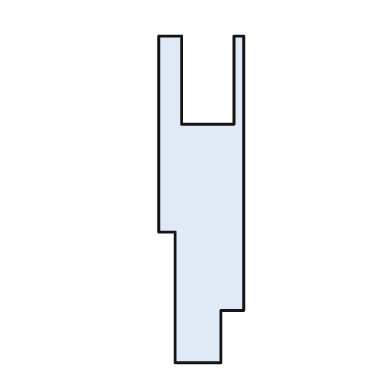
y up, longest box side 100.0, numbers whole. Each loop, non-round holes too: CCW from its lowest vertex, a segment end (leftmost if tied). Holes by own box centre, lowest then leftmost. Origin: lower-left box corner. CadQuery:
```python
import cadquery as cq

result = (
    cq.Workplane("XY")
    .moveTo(5.0, 0.0)
    .lineTo(19.0, 0.0)
    .lineTo(19.0, 16.0)
    .lineTo(26.0, 16.0)
    .lineTo(26.0, 100.0)
    .lineTo(23.0, 100.0)
    .lineTo(23.0, 73.0)
    .lineTo(7.0, 73.0)
    .lineTo(7.0, 100.0)
    .lineTo(0.0, 100.0)
    .lineTo(0.0, 40.0)
    .lineTo(5.0, 40.0)
    .close()
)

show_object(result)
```